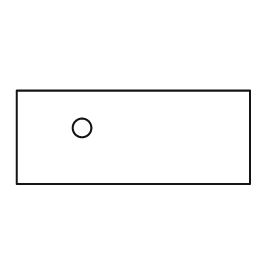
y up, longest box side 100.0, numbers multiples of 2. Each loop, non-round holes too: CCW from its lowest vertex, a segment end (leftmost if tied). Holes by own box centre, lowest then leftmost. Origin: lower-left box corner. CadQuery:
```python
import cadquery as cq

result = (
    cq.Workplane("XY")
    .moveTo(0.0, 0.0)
    .lineTo(100.0, 0.0)
    .lineTo(100.0, 40.0)
    .lineTo(0.0, 40.0)
    .close()
    .moveTo(28.0, 24.0)
    .circle(4.0)
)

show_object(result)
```